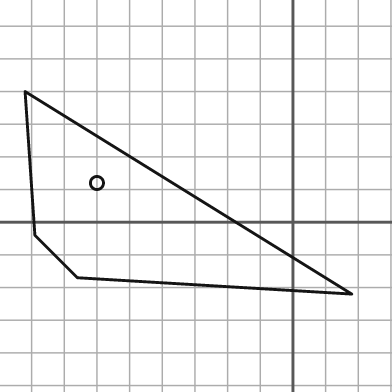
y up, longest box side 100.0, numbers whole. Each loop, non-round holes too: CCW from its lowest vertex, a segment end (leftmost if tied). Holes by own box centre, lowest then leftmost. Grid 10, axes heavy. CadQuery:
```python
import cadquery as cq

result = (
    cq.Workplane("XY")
    .moveTo(18.0, -22.0)
    .lineTo(-82.0, 40.0)
    .lineTo(-79.0, -4.0)
    .lineTo(-66.0, -17.0)
    .close()
    .moveTo(-60.0, 12.0)
    .circle(2.0)
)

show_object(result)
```